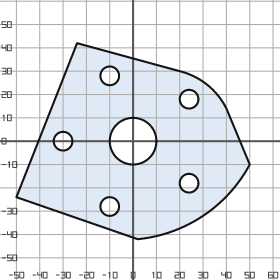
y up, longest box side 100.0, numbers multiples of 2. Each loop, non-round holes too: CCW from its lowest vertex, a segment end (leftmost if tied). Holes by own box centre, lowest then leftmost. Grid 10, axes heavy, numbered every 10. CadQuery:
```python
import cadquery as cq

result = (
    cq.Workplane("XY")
    .moveTo(2.0, -42.0)
    .threePointArc((30.0, -32.0), (50.0, -10.0))
    .lineTo(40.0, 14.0)
    .threePointArc((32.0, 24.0), (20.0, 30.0))
    .lineTo(-24.0, 42.0)
    .lineTo(-50.0, -24.0)
    .close()
    .moveTo(-10.0, -28.0)
    .circle(4.0)
    .moveTo(24.0, -18.0)
    .circle(4.0)
    .moveTo(-30.0, 0.0)
    .circle(4.0)
    .moveTo(0.0, 0.0)
    .circle(10.0)
    .moveTo(24.0, 18.0)
    .circle(4.0)
    .moveTo(-10.0, 28.0)
    .circle(4.0)
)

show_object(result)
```